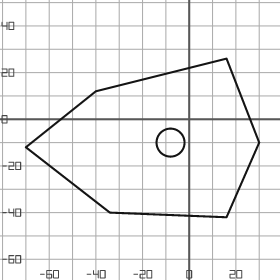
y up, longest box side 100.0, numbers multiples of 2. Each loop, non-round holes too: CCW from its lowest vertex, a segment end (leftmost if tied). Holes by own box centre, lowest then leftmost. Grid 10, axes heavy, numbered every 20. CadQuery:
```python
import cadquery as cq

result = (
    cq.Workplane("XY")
    .moveTo(16.0, -42.0)
    .lineTo(30.0, -10.0)
    .lineTo(16.0, 26.0)
    .lineTo(-40.0, 12.0)
    .lineTo(-70.0, -12.0)
    .lineTo(-34.0, -40.0)
    .close()
    .moveTo(-8.0, -10.0)
    .circle(6.0)
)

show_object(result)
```